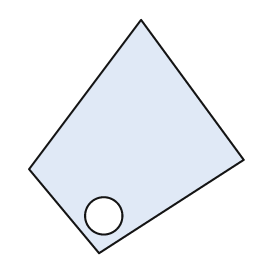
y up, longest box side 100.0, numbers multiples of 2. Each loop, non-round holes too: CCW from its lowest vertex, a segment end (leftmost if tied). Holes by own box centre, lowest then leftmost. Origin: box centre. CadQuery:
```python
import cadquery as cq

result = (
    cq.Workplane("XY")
    .moveTo(-16.0, -50.0)
    .lineTo(46.0, -10.0)
    .lineTo(2.0, 50.0)
    .lineTo(-46.0, -14.0)
    .close()
    .moveTo(-14.0, -34.0)
    .circle(8.0)
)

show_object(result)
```